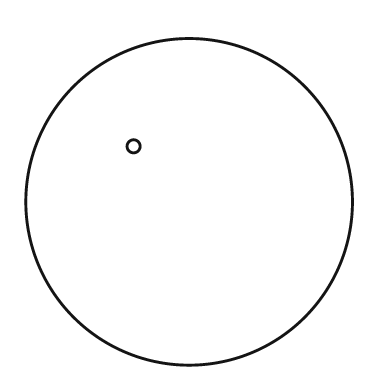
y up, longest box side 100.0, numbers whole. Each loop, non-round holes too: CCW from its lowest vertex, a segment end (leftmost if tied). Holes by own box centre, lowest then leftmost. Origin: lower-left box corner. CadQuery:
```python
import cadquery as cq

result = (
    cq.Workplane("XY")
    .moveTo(50.0, 50.0)
    .circle(50.0)
    .moveTo(33.0, 67.0)
    .circle(2.0)
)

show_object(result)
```